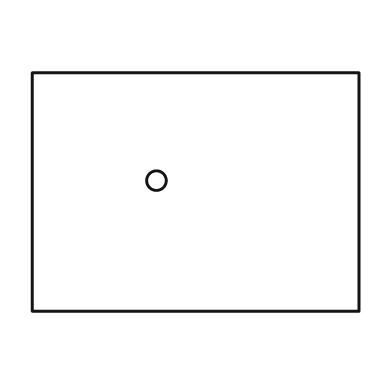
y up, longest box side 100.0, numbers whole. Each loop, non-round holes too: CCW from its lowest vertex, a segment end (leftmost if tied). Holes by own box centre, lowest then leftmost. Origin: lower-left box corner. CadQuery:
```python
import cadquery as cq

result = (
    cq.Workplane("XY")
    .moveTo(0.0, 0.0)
    .lineTo(100.0, 0.0)
    .lineTo(100.0, 73.0)
    .lineTo(0.0, 73.0)
    .close()
    .moveTo(38.0, 40.0)
    .circle(3.0)
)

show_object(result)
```